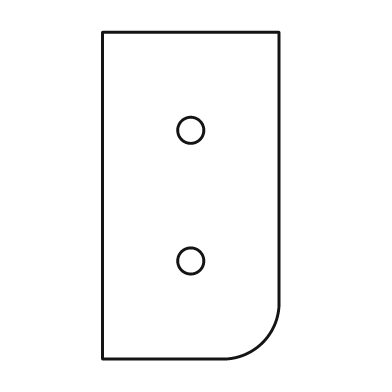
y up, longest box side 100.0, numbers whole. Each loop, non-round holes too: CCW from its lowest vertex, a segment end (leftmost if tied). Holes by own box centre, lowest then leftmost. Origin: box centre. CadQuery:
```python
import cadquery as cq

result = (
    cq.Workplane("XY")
    .moveTo(-27.0, -50.0)
    .lineTo(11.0, -50.0)
    .threePointArc((22.0, -45.0), (27.0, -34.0))
    .lineTo(27.0, 50.0)
    .lineTo(-27.0, 50.0)
    .close()
    .moveTo(0.0, -20.0)
    .circle(4.0)
    .moveTo(0.0, 20.0)
    .circle(4.0)
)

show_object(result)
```